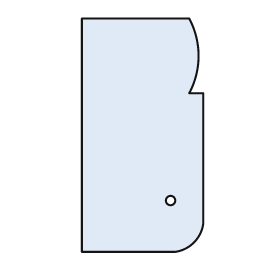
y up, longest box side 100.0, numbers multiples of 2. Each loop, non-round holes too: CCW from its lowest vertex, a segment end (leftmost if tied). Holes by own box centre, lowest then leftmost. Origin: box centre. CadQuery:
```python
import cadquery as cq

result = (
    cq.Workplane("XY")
    .moveTo(-26.0, -50.0)
    .lineTo(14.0, -50.0)
    .threePointArc((22.0, -46.0), (26.0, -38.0))
    .lineTo(26.0, 18.0)
    .lineTo(20.0, 18.0)
    .threePointArc((24.0, 34.0), (20.0, 50.0))
    .lineTo(-26.0, 50.0)
    .close()
    .moveTo(12.0, -28.0)
    .circle(2.0)
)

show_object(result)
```